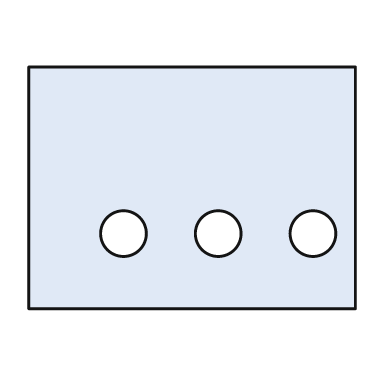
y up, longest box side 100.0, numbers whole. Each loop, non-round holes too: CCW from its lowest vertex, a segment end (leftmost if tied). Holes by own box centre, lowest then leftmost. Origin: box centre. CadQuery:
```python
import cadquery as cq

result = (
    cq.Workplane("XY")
    .moveTo(-50.0, -37.0)
    .lineTo(50.0, -37.0)
    .lineTo(50.0, 37.0)
    .lineTo(-50.0, 37.0)
    .close()
    .moveTo(-21.0, -14.0)
    .circle(7.0)
    .moveTo(8.0, -14.0)
    .circle(7.0)
    .moveTo(37.0, -14.0)
    .circle(7.0)
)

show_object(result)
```